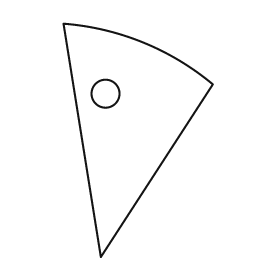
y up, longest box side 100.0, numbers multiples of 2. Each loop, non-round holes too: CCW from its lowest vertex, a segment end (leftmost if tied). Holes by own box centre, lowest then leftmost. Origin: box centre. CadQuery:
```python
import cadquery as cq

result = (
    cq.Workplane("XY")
    .moveTo(-16.0, -50.0)
    .lineTo(32.0, 24.0)
    .threePointArc((2.0, 42.0), (-32.0, 50.0))
    .close()
    .moveTo(-14.0, 20.0)
    .circle(6.0)
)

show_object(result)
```